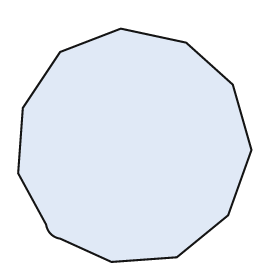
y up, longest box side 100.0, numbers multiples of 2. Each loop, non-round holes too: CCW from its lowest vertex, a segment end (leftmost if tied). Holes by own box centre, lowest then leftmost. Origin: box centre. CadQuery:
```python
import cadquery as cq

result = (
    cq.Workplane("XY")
    .moveTo(-10.0, -50.0)
    .lineTo(18.0, -48.0)
    .lineTo(40.0, -30.0)
    .lineTo(50.0, -2.0)
    .lineTo(42.0, 26.0)
    .lineTo(22.0, 44.0)
    .lineTo(-6.0, 50.0)
    .lineTo(-32.0, 40.0)
    .lineTo(-48.0, 16.0)
    .lineTo(-50.0, -12.0)
    .lineTo(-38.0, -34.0)
    .threePointArc((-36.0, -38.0), (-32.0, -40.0))
    .close()
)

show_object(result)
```